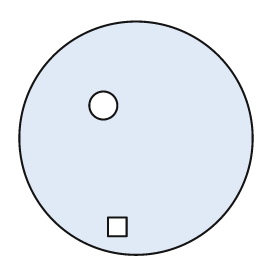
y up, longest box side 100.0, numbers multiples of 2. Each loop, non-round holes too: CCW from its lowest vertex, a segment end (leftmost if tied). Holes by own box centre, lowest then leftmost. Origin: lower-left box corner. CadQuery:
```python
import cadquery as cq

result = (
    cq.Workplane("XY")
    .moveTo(50.0, 50.0)
    .circle(50.0)
    .moveTo(38.0, 8.0)
    .lineTo(46.0, 8.0)
    .lineTo(46.0, 16.0)
    .lineTo(38.0, 16.0)
    .close()
    .moveTo(36.0, 64.0)
    .circle(6.0)
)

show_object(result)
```